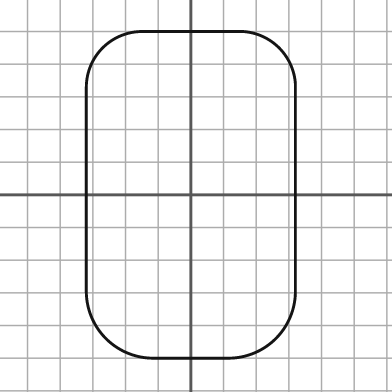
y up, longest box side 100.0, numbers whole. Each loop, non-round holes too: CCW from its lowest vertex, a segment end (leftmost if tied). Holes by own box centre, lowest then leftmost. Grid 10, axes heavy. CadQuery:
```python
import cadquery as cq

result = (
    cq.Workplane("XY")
    .moveTo(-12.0, -50.0)
    .lineTo(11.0, -50.0)
    .threePointArc((26.0, -44.0), (32.0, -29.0))
    .lineTo(32.0, 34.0)
    .threePointArc((27.0, 45.0), (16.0, 50.0))
    .lineTo(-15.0, 50.0)
    .threePointArc((-27.0, 45.0), (-32.0, 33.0))
    .lineTo(-32.0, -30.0)
    .threePointArc((-26.0, -44.0), (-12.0, -50.0))
    .close()
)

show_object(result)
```